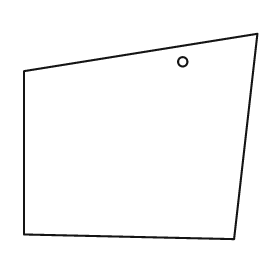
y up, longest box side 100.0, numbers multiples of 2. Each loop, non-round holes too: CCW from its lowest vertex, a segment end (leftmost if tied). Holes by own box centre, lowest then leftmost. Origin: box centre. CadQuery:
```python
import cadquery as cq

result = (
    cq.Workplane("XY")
    .moveTo(40.0, -44.0)
    .lineTo(50.0, 44.0)
    .lineTo(-50.0, 28.0)
    .lineTo(-50.0, -42.0)
    .close()
    .moveTo(18.0, 32.0)
    .circle(2.0)
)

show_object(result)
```